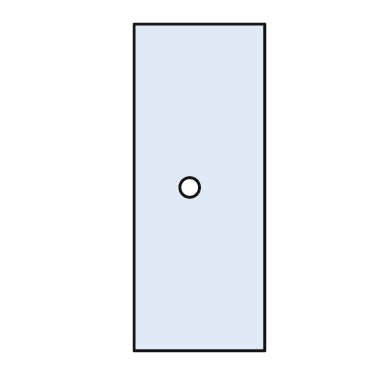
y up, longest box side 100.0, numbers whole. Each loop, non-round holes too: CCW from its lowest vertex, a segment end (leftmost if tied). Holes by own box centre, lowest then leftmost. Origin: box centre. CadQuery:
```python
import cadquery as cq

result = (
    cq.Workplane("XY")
    .moveTo(-20.0, -50.0)
    .lineTo(20.0, -50.0)
    .lineTo(20.0, 50.0)
    .lineTo(-20.0, 50.0)
    .close()
    .moveTo(-3.0, 0.0)
    .circle(3.0)
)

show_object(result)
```